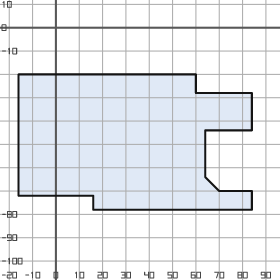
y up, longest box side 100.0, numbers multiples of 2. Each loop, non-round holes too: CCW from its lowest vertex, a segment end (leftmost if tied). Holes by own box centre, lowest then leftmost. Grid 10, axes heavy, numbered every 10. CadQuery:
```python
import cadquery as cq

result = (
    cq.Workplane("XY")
    .moveTo(16.0, -78.0)
    .lineTo(84.0, -78.0)
    .lineTo(84.0, -70.0)
    .lineTo(70.0, -70.0)
    .lineTo(64.0, -64.0)
    .lineTo(64.0, -44.0)
    .lineTo(84.0, -44.0)
    .lineTo(84.0, -28.0)
    .lineTo(60.0, -28.0)
    .lineTo(60.0, -20.0)
    .lineTo(-16.0, -20.0)
    .lineTo(-16.0, -72.0)
    .lineTo(16.0, -72.0)
    .close()
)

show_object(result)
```